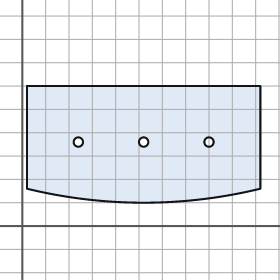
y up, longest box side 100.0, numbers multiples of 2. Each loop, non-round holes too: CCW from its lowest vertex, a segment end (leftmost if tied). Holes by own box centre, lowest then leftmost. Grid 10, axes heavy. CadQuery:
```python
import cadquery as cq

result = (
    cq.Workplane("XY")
    .moveTo(2.0, 16.0)
    .threePointArc((52.0, 10.0), (102.0, 16.0))
    .lineTo(102.0, 60.0)
    .lineTo(2.0, 60.0)
    .close()
    .moveTo(24.0, 36.0)
    .circle(2.0)
    .moveTo(52.0, 36.0)
    .circle(2.0)
    .moveTo(80.0, 36.0)
    .circle(2.0)
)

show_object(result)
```